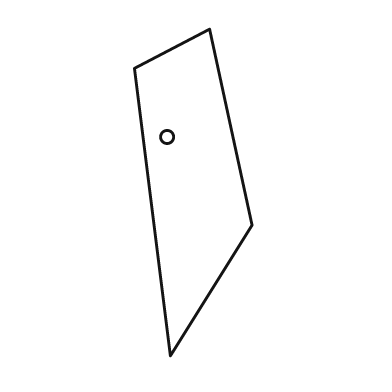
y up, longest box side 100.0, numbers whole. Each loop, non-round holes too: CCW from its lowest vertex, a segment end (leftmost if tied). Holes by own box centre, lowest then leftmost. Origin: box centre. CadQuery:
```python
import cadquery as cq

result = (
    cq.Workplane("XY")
    .moveTo(-7.0, -50.0)
    .lineTo(18.0, -10.0)
    .lineTo(5.0, 50.0)
    .lineTo(-18.0, 38.0)
    .close()
    .moveTo(-8.0, 17.0)
    .circle(2.0)
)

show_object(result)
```